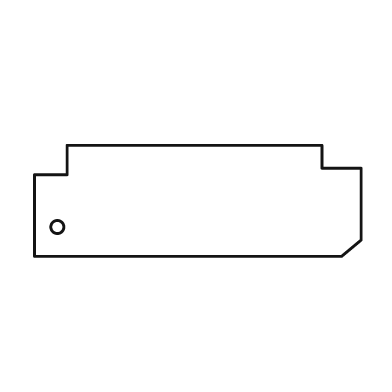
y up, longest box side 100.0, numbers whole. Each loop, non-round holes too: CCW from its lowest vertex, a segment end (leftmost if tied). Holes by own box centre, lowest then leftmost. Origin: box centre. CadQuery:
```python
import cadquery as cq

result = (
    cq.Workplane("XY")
    .moveTo(-50.0, -17.0)
    .lineTo(44.0, -17.0)
    .lineTo(50.0, -12.0)
    .lineTo(50.0, 10.0)
    .lineTo(38.0, 10.0)
    .lineTo(38.0, 17.0)
    .lineTo(-40.0, 17.0)
    .lineTo(-40.0, 8.0)
    .lineTo(-50.0, 8.0)
    .close()
    .moveTo(-43.0, -8.0)
    .circle(2.0)
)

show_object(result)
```